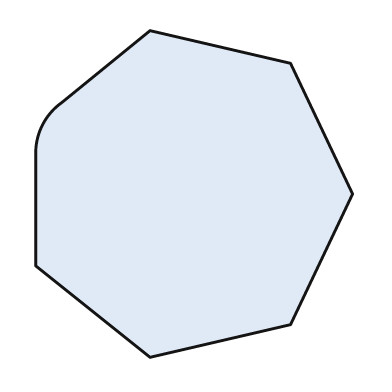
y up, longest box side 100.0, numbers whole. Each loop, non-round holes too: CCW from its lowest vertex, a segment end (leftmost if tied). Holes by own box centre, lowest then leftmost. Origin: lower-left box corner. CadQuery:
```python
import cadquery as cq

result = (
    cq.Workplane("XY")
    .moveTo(35.0, 0.0)
    .lineTo(78.0, 10.0)
    .lineTo(97.0, 50.0)
    .lineTo(78.0, 90.0)
    .lineTo(35.0, 100.0)
    .lineTo(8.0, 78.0)
    .threePointArc((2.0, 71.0), (0.0, 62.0))
    .lineTo(0.0, 28.0)
    .close()
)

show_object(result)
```